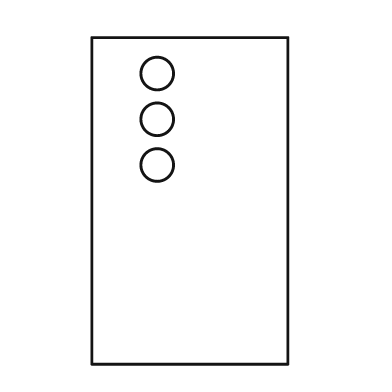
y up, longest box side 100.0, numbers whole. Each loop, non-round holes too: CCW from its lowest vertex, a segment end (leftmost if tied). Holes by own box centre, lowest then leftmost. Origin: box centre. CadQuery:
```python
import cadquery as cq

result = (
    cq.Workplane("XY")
    .moveTo(-30.0, -50.0)
    .lineTo(30.0, -50.0)
    .lineTo(30.0, 50.0)
    .lineTo(-30.0, 50.0)
    .close()
    .moveTo(-10.0, 11.0)
    .circle(5.0)
    .moveTo(-10.0, 25.0)
    .circle(5.0)
    .moveTo(-10.0, 39.0)
    .circle(5.0)
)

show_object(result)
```